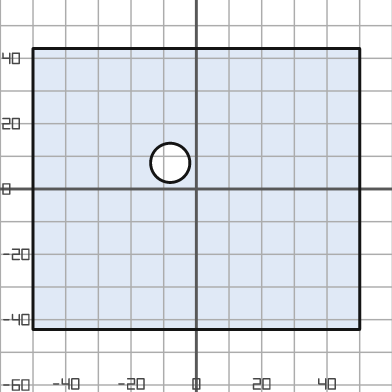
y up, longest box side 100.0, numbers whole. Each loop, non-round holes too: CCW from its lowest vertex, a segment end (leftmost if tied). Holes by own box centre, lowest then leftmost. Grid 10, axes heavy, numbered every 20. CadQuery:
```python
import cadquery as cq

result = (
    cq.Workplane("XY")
    .moveTo(-50.0, -43.0)
    .lineTo(50.0, -43.0)
    .lineTo(50.0, 43.0)
    .lineTo(-50.0, 43.0)
    .close()
    .moveTo(-8.0, 8.0)
    .circle(6.0)
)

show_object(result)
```